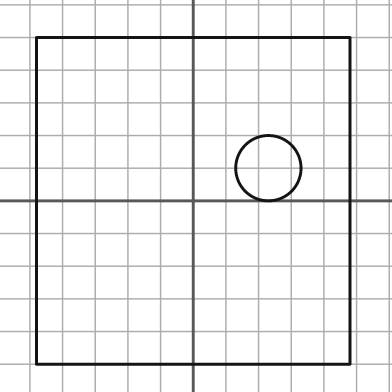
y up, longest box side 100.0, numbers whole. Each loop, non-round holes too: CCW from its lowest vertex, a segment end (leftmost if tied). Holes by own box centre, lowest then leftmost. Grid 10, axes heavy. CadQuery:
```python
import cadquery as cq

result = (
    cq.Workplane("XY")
    .moveTo(-48.0, -50.0)
    .lineTo(48.0, -50.0)
    .lineTo(48.0, 50.0)
    .lineTo(-48.0, 50.0)
    .close()
    .moveTo(23.0, 10.0)
    .circle(10.0)
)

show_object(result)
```